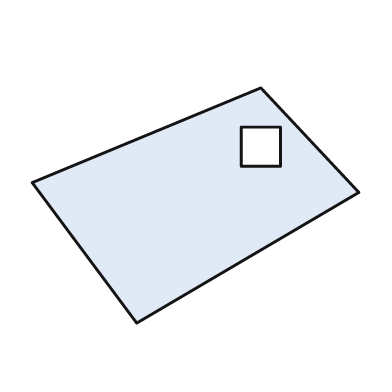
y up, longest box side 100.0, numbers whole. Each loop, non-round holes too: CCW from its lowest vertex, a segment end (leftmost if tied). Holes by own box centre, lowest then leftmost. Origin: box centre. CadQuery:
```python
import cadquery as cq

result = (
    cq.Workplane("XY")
    .moveTo(-18.0, -36.0)
    .lineTo(50.0, 4.0)
    .lineTo(20.0, 36.0)
    .lineTo(-50.0, 7.0)
    .close()
    .moveTo(14.0, 12.0)
    .lineTo(26.0, 12.0)
    .lineTo(26.0, 24.0)
    .lineTo(14.0, 24.0)
    .close()
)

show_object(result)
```